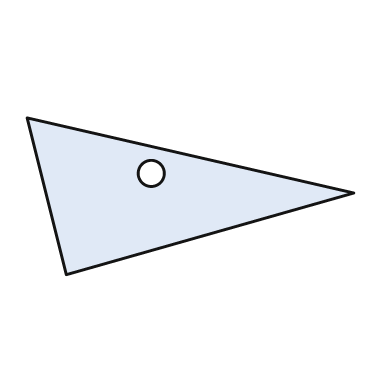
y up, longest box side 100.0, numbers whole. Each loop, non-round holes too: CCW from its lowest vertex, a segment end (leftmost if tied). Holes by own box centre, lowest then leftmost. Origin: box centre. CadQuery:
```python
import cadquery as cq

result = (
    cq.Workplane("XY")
    .moveTo(-38.0, -24.0)
    .lineTo(50.0, 1.0)
    .lineTo(-50.0, 24.0)
    .close()
    .moveTo(-12.0, 7.0)
    .circle(4.0)
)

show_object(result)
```